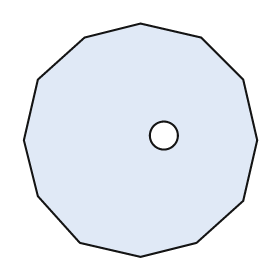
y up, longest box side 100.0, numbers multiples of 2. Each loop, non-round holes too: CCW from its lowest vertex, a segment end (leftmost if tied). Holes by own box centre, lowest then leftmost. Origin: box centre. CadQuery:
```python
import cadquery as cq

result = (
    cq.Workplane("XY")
    .moveTo(0.0, -50.0)
    .lineTo(24.0, -44.0)
    .lineTo(44.0, -26.0)
    .lineTo(50.0, 0.0)
    .lineTo(44.0, 26.0)
    .lineTo(26.0, 44.0)
    .lineTo(0.0, 50.0)
    .lineTo(-24.0, 44.0)
    .lineTo(-44.0, 26.0)
    .lineTo(-50.0, 0.0)
    .lineTo(-44.0, -24.0)
    .lineTo(-26.0, -44.0)
    .close()
    .moveTo(10.0, 2.0)
    .circle(6.0)
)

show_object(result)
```